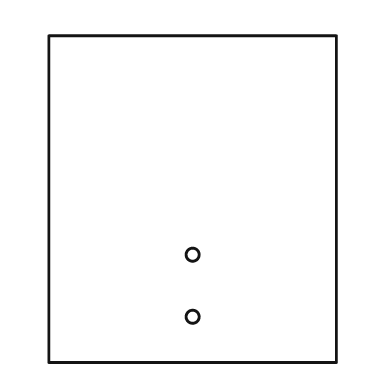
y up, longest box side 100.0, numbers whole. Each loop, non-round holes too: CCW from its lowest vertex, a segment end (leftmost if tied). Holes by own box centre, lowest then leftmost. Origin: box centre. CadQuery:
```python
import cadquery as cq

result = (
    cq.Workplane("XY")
    .moveTo(-44.0, -50.0)
    .lineTo(44.0, -50.0)
    .lineTo(44.0, 50.0)
    .lineTo(-44.0, 50.0)
    .close()
    .moveTo(0.0, -36.0)
    .circle(2.0)
    .moveTo(0.0, -17.0)
    .circle(2.0)
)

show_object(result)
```